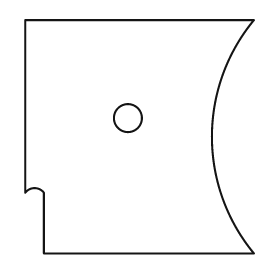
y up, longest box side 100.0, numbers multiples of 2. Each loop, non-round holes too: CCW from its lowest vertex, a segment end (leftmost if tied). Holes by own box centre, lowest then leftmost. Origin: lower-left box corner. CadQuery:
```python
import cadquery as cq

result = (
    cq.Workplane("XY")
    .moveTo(8.0, 0.0)
    .lineTo(98.0, 0.0)
    .threePointArc((80.0, 50.0), (98.0, 100.0))
    .lineTo(0.0, 100.0)
    .lineTo(0.0, 26.0)
    .threePointArc((4.0, 28.0), (8.0, 26.0))
    .close()
    .moveTo(44.0, 58.0)
    .circle(6.0)
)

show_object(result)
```